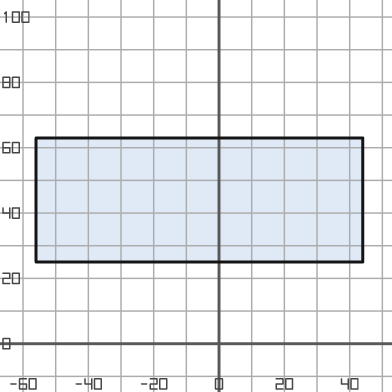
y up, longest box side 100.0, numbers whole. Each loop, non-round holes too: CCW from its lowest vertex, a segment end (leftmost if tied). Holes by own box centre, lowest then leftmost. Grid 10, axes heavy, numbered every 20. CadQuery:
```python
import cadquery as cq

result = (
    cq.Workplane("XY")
    .moveTo(-56.0, 25.0)
    .lineTo(44.0, 25.0)
    .lineTo(44.0, 63.0)
    .lineTo(-56.0, 63.0)
    .close()
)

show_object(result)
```